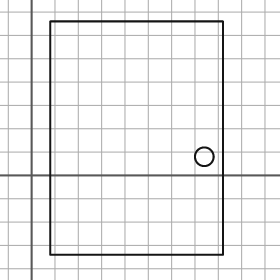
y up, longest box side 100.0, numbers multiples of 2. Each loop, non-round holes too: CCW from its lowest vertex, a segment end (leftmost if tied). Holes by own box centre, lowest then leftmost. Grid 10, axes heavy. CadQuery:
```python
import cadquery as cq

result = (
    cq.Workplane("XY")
    .moveTo(8.0, -34.0)
    .lineTo(82.0, -34.0)
    .lineTo(82.0, 66.0)
    .lineTo(8.0, 66.0)
    .close()
    .moveTo(74.0, 8.0)
    .circle(4.0)
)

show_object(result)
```